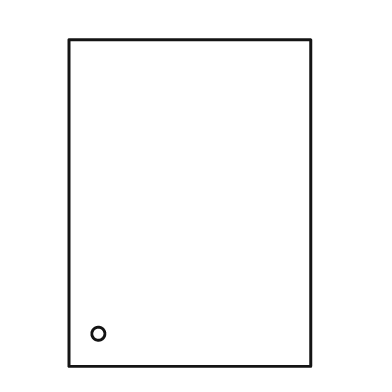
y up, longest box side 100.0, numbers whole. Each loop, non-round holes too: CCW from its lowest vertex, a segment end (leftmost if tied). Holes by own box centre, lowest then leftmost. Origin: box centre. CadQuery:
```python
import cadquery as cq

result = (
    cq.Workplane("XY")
    .moveTo(-37.0, -50.0)
    .lineTo(37.0, -50.0)
    .lineTo(37.0, 50.0)
    .lineTo(-37.0, 50.0)
    .close()
    .moveTo(-28.0, -40.0)
    .circle(2.0)
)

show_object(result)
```